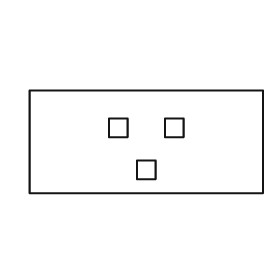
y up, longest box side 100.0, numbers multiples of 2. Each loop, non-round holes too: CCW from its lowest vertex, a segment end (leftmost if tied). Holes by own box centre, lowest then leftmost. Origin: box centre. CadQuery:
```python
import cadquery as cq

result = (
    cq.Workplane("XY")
    .moveTo(-50.0, -22.0)
    .lineTo(50.0, -22.0)
    .lineTo(50.0, 22.0)
    .lineTo(-50.0, 22.0)
    .close()
    .moveTo(-4.0, -16.0)
    .lineTo(4.0, -16.0)
    .lineTo(4.0, -8.0)
    .lineTo(-4.0, -8.0)
    .close()
    .moveTo(-16.0, 2.0)
    .lineTo(-8.0, 2.0)
    .lineTo(-8.0, 10.0)
    .lineTo(-16.0, 10.0)
    .close()
    .moveTo(8.0, 2.0)
    .lineTo(16.0, 2.0)
    .lineTo(16.0, 10.0)
    .lineTo(8.0, 10.0)
    .close()
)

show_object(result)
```